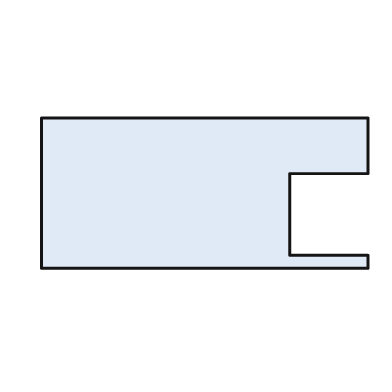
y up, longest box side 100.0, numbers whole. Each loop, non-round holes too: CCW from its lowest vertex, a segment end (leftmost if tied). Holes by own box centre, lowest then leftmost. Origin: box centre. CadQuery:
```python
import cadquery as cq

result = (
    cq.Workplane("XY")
    .moveTo(-50.0, -23.0)
    .lineTo(50.0, -23.0)
    .lineTo(50.0, -19.0)
    .lineTo(26.0, -19.0)
    .lineTo(26.0, 6.0)
    .lineTo(50.0, 6.0)
    .lineTo(50.0, 23.0)
    .lineTo(-50.0, 23.0)
    .close()
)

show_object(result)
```